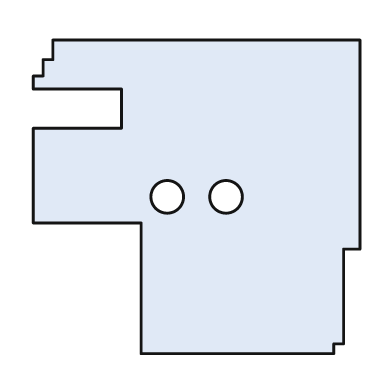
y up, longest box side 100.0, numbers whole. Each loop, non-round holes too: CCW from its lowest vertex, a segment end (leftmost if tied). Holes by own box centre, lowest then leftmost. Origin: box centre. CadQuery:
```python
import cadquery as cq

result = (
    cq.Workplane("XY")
    .moveTo(-17.0, -48.0)
    .lineTo(42.0, -48.0)
    .lineTo(42.0, -45.0)
    .lineTo(45.0, -45.0)
    .lineTo(45.0, -16.0)
    .lineTo(50.0, -16.0)
    .lineTo(50.0, 48.0)
    .lineTo(-44.0, 48.0)
    .lineTo(-44.0, 42.0)
    .lineTo(-47.0, 42.0)
    .lineTo(-47.0, 37.0)
    .lineTo(-50.0, 37.0)
    .lineTo(-50.0, 33.0)
    .lineTo(-23.0, 33.0)
    .lineTo(-23.0, 21.0)
    .lineTo(-50.0, 21.0)
    .lineTo(-50.0, -8.0)
    .lineTo(-17.0, -8.0)
    .close()
    .moveTo(-9.0, 0.0)
    .circle(5.0)
    .moveTo(9.0, 0.0)
    .circle(5.0)
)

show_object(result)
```